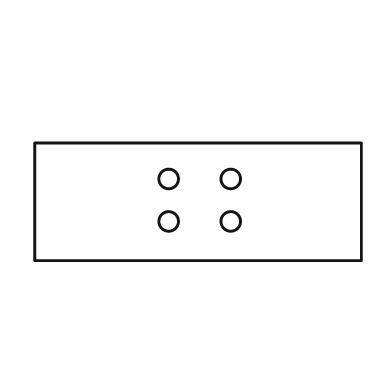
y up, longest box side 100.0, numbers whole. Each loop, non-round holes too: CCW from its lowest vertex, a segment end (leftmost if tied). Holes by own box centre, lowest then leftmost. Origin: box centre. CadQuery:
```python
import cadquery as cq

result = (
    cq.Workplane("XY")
    .moveTo(-50.0, -18.0)
    .lineTo(50.0, -18.0)
    .lineTo(50.0, 18.0)
    .lineTo(-50.0, 18.0)
    .close()
    .moveTo(-9.0, -6.0)
    .circle(3.0)
    .moveTo(10.0, -6.0)
    .circle(3.0)
    .moveTo(-9.0, 7.0)
    .circle(3.0)
    .moveTo(10.0, 7.0)
    .circle(3.0)
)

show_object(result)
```